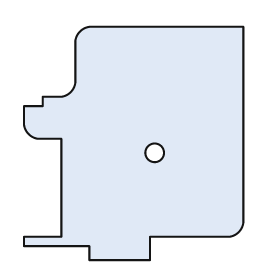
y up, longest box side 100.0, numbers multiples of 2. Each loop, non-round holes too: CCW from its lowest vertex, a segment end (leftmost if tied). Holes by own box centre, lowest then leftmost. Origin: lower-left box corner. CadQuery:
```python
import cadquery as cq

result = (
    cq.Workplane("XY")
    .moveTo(28.0, 0.0)
    .lineTo(54.0, 0.0)
    .lineTo(54.0, 10.0)
    .lineTo(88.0, 10.0)
    .threePointArc((92.0, 12.0), (94.0, 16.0))
    .lineTo(94.0, 100.0)
    .lineTo(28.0, 100.0)
    .threePointArc((24.0, 98.0), (22.0, 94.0))
    .lineTo(22.0, 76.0)
    .threePointArc((20.0, 72.0), (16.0, 70.0))
    .lineTo(8.0, 70.0)
    .lineTo(8.0, 66.0)
    .lineTo(0.0, 66.0)
    .lineTo(0.0, 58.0)
    .threePointArc((2.0, 54.0), (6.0, 52.0))
    .lineTo(16.0, 52.0)
    .lineTo(16.0, 10.0)
    .lineTo(0.0, 10.0)
    .lineTo(0.0, 6.0)
    .lineTo(28.0, 6.0)
    .close()
    .moveTo(56.0, 46.0)
    .circle(4.0)
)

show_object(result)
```